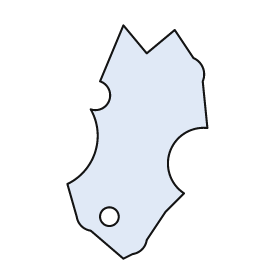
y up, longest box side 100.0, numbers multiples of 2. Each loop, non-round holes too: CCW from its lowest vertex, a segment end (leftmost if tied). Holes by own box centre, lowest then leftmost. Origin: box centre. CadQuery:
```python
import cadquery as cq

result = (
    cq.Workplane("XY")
    .moveTo(-6.0, -50.0)
    .lineTo(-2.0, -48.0)
    .threePointArc((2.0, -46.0), (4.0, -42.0))
    .lineTo(12.0, -30.0)
    .lineTo(20.0, -22.0)
    .threePointArc((14.0, -4.0), (30.0, 6.0))
    .lineTo(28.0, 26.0)
    .threePointArc((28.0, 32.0), (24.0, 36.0))
    .lineTo(16.0, 48.0)
    .lineTo(4.0, 38.0)
    .lineTo(-6.0, 50.0)
    .lineTo(-16.0, 26.0)
    .threePointArc((-12.0, 18.0), (-20.0, 14.0))
    .threePointArc((-18.0, -4.0), (-30.0, -18.0))
    .lineTo(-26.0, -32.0)
    .threePointArc((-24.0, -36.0), (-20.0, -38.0))
    .close()
    .moveTo(-12.0, -32.0)
    .circle(4.0)
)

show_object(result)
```